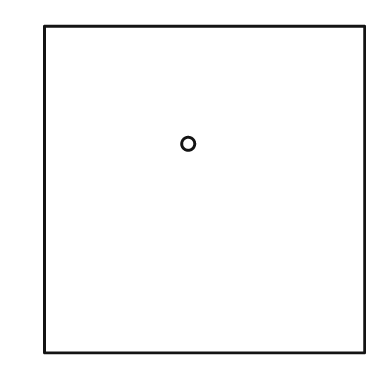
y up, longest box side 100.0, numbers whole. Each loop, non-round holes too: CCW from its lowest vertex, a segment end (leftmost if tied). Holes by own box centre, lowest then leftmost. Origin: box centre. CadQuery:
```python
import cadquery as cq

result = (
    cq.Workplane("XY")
    .moveTo(-49.0, -50.0)
    .lineTo(49.0, -50.0)
    .lineTo(49.0, 50.0)
    .lineTo(-49.0, 50.0)
    .close()
    .moveTo(-5.0, 14.0)
    .circle(2.0)
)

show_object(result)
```